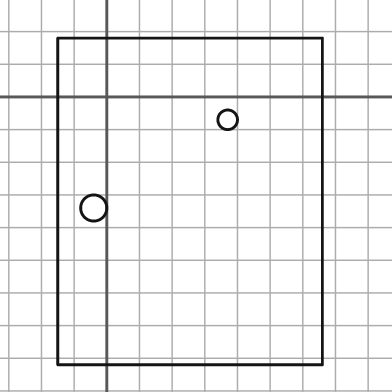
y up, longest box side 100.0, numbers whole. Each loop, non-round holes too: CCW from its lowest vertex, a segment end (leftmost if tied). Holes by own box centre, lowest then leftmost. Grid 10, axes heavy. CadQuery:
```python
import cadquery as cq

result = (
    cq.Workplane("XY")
    .moveTo(-15.0, -82.0)
    .lineTo(66.0, -82.0)
    .lineTo(66.0, 18.0)
    .lineTo(-15.0, 18.0)
    .close()
    .moveTo(-4.0, -34.0)
    .circle(4.0)
    .moveTo(37.0, -7.0)
    .circle(3.0)
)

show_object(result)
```